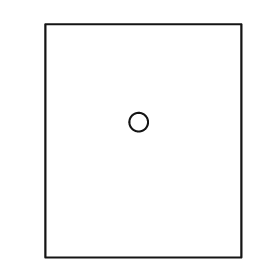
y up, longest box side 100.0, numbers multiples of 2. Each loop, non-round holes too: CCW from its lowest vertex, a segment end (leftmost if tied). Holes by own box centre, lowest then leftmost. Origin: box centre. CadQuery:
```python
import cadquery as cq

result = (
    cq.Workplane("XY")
    .moveTo(-42.0, -50.0)
    .lineTo(42.0, -50.0)
    .lineTo(42.0, 50.0)
    .lineTo(-42.0, 50.0)
    .close()
    .moveTo(-2.0, 8.0)
    .circle(4.0)
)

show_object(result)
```